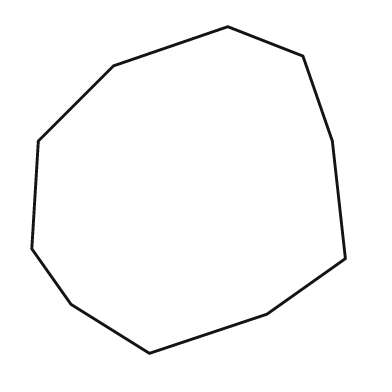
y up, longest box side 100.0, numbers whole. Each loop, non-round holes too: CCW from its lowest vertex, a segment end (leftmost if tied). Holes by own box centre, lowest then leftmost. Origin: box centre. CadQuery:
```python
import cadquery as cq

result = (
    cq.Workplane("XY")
    .moveTo(-12.0, -50.0)
    .lineTo(24.0, -38.0)
    .lineTo(48.0, -21.0)
    .lineTo(44.0, 15.0)
    .lineTo(35.0, 41.0)
    .lineTo(12.0, 50.0)
    .lineTo(-23.0, 38.0)
    .lineTo(-46.0, 15.0)
    .lineTo(-48.0, -18.0)
    .lineTo(-36.0, -35.0)
    .close()
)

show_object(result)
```